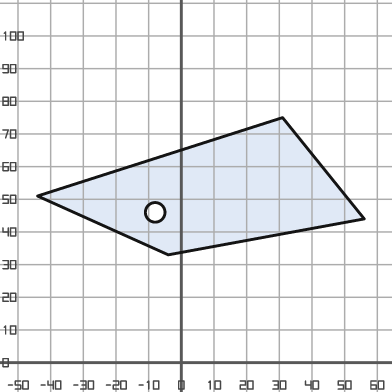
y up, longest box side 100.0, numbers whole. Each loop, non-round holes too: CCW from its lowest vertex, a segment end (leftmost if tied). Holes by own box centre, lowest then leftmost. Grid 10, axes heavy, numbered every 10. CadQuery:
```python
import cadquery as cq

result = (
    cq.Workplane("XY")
    .moveTo(-4.0, 33.0)
    .lineTo(56.0, 44.0)
    .lineTo(31.0, 75.0)
    .lineTo(-44.0, 51.0)
    .close()
    .moveTo(-8.0, 46.0)
    .circle(3.0)
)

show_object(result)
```